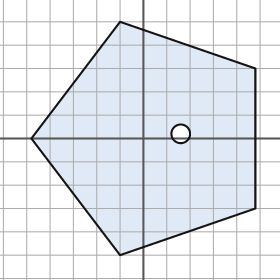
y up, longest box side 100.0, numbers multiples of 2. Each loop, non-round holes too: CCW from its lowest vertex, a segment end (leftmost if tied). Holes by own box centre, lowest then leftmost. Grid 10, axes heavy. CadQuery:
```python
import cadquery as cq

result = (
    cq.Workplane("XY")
    .moveTo(-10.0, -50.0)
    .lineTo(48.0, -30.0)
    .lineTo(48.0, 30.0)
    .lineTo(-10.0, 50.0)
    .lineTo(-48.0, 0.0)
    .close()
    .moveTo(16.0, 2.0)
    .circle(4.0)
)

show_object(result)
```